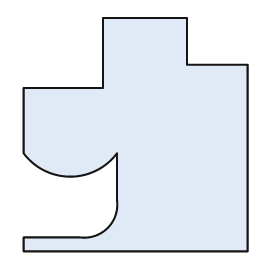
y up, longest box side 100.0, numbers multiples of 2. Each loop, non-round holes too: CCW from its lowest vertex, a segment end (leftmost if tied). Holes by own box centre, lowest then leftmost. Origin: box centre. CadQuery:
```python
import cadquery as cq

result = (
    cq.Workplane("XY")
    .moveTo(-48.0, -50.0)
    .lineTo(48.0, -50.0)
    .lineTo(48.0, 30.0)
    .lineTo(22.0, 30.0)
    .lineTo(22.0, 50.0)
    .lineTo(-14.0, 50.0)
    .lineTo(-14.0, 20.0)
    .lineTo(-48.0, 20.0)
    .lineTo(-48.0, -8.0)
    .threePointArc((-28.0, -18.0), (-8.0, -8.0))
    .lineTo(-8.0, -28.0)
    .threePointArc((-12.0, -40.0), (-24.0, -44.0))
    .lineTo(-48.0, -44.0)
    .close()
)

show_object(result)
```